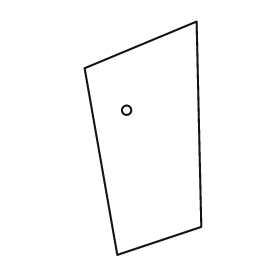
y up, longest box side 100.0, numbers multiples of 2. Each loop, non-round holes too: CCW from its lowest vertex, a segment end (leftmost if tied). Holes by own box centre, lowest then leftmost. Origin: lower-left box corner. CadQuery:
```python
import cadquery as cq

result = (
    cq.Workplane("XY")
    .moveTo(14.0, 0.0)
    .lineTo(50.0, 12.0)
    .lineTo(48.0, 100.0)
    .lineTo(0.0, 80.0)
    .close()
    .moveTo(18.0, 62.0)
    .circle(2.0)
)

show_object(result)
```